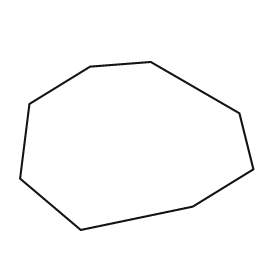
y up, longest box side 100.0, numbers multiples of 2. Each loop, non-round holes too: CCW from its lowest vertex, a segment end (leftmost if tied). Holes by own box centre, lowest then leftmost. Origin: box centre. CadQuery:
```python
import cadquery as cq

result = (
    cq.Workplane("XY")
    .moveTo(-24.0, -36.0)
    .lineTo(24.0, -26.0)
    .lineTo(50.0, -10.0)
    .lineTo(44.0, 14.0)
    .lineTo(6.0, 36.0)
    .lineTo(-20.0, 34.0)
    .lineTo(-46.0, 18.0)
    .lineTo(-50.0, -14.0)
    .close()
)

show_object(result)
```